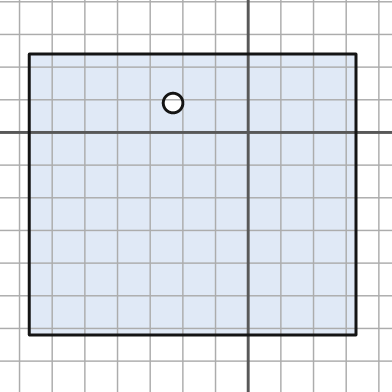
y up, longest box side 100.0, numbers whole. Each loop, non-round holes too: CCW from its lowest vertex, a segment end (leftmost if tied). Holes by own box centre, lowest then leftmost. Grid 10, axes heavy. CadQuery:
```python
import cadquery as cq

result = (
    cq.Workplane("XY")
    .moveTo(-67.0, -62.0)
    .lineTo(33.0, -62.0)
    .lineTo(33.0, 24.0)
    .lineTo(-67.0, 24.0)
    .close()
    .moveTo(-23.0, 9.0)
    .circle(3.0)
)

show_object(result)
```